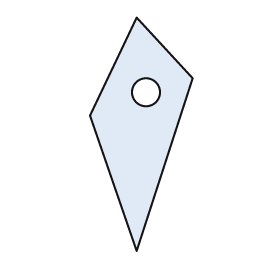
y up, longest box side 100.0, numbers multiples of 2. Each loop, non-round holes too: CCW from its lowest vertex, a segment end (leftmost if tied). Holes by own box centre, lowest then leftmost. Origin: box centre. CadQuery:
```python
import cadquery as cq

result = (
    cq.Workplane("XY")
    .moveTo(-2.0, -50.0)
    .lineTo(22.0, 24.0)
    .lineTo(-2.0, 50.0)
    .lineTo(-22.0, 8.0)
    .close()
    .moveTo(2.0, 18.0)
    .circle(6.0)
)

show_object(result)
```